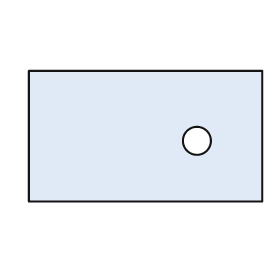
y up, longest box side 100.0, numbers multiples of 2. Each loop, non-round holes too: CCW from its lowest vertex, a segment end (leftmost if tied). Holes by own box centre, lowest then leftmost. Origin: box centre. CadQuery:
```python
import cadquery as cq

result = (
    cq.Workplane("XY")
    .moveTo(-50.0, -28.0)
    .lineTo(50.0, -28.0)
    .lineTo(50.0, 28.0)
    .lineTo(-50.0, 28.0)
    .close()
    .moveTo(22.0, -2.0)
    .circle(6.0)
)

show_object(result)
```